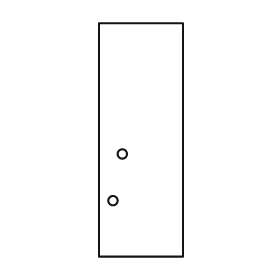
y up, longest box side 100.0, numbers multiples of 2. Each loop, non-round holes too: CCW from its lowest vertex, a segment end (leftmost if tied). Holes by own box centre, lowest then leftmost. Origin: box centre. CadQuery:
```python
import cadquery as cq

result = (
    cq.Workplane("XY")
    .moveTo(-18.0, -50.0)
    .lineTo(18.0, -50.0)
    .lineTo(18.0, 50.0)
    .lineTo(-18.0, 50.0)
    .close()
    .moveTo(-12.0, -26.0)
    .circle(2.0)
    .moveTo(-8.0, -6.0)
    .circle(2.0)
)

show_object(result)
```